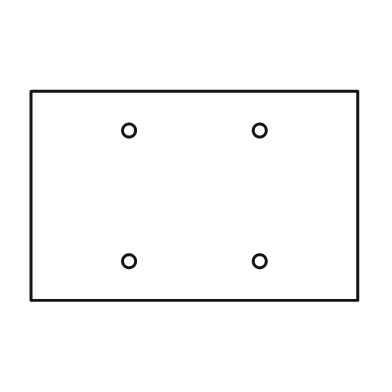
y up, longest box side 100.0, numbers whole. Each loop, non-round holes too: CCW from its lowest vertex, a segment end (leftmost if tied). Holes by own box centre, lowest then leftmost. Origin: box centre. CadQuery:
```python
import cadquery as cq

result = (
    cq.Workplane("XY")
    .moveTo(-50.0, -32.0)
    .lineTo(50.0, -32.0)
    .lineTo(50.0, 32.0)
    .lineTo(-50.0, 32.0)
    .close()
    .moveTo(-20.0, -20.0)
    .circle(2.0)
    .moveTo(20.0, -20.0)
    .circle(2.0)
    .moveTo(-20.0, 20.0)
    .circle(2.0)
    .moveTo(20.0, 20.0)
    .circle(2.0)
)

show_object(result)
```